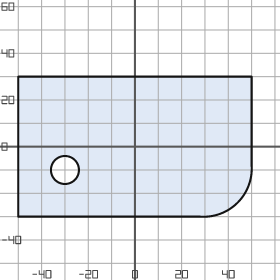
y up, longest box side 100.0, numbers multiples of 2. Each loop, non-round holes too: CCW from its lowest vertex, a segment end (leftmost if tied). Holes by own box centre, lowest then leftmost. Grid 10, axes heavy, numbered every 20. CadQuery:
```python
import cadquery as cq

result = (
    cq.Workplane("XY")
    .moveTo(-50.0, -30.0)
    .lineTo(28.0, -30.0)
    .threePointArc((44.0, -24.0), (50.0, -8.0))
    .lineTo(50.0, 30.0)
    .lineTo(-50.0, 30.0)
    .close()
    .moveTo(-30.0, -10.0)
    .circle(6.0)
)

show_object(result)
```